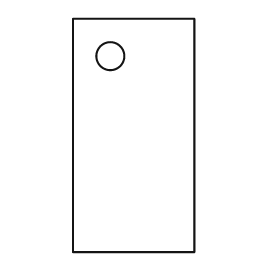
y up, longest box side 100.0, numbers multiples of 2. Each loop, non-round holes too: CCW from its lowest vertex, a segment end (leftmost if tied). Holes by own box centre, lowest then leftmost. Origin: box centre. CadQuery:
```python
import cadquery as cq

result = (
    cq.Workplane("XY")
    .moveTo(-26.0, -50.0)
    .lineTo(26.0, -50.0)
    .lineTo(26.0, 50.0)
    .lineTo(-26.0, 50.0)
    .close()
    .moveTo(-10.0, 34.0)
    .circle(6.0)
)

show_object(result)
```